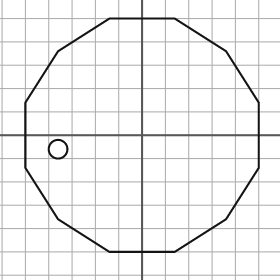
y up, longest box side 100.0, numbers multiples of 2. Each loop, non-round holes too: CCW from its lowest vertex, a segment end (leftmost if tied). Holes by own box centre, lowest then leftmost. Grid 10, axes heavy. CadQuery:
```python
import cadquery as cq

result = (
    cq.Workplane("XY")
    .moveTo(-14.0, -50.0)
    .lineTo(14.0, -50.0)
    .lineTo(36.0, -36.0)
    .lineTo(50.0, -14.0)
    .lineTo(50.0, 14.0)
    .lineTo(36.0, 36.0)
    .lineTo(14.0, 50.0)
    .lineTo(-14.0, 50.0)
    .lineTo(-36.0, 36.0)
    .lineTo(-50.0, 14.0)
    .lineTo(-50.0, -14.0)
    .lineTo(-36.0, -36.0)
    .close()
    .moveTo(-36.0, -6.0)
    .circle(4.0)
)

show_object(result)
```